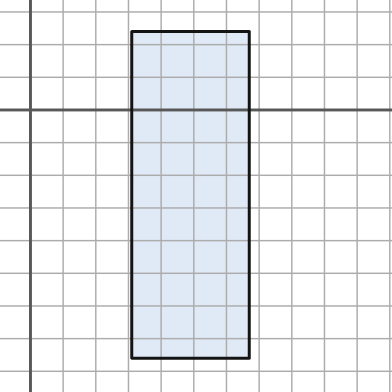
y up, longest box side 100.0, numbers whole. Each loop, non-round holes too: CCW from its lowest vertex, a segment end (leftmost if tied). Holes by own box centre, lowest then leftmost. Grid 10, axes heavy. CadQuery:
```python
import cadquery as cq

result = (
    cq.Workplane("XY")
    .moveTo(31.0, -76.0)
    .lineTo(67.0, -76.0)
    .lineTo(67.0, 24.0)
    .lineTo(31.0, 24.0)
    .close()
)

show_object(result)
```